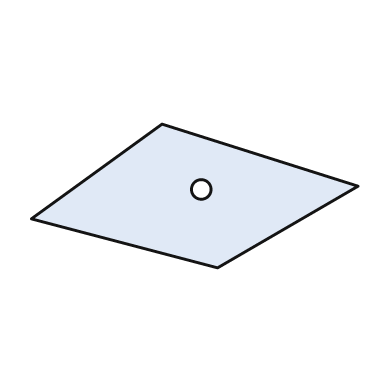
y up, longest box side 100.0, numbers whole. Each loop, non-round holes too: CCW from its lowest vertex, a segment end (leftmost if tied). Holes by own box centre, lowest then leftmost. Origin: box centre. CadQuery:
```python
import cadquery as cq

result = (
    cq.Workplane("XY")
    .moveTo(7.0, -22.0)
    .lineTo(50.0, 3.0)
    .lineTo(-10.0, 22.0)
    .lineTo(-50.0, -7.0)
    .close()
    .moveTo(2.0, 2.0)
    .circle(3.0)
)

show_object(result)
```